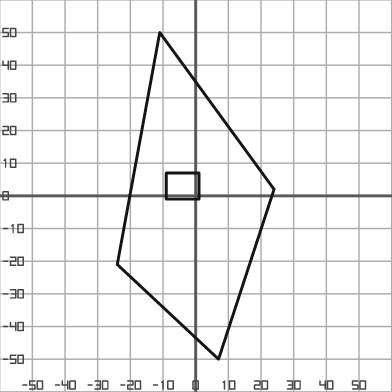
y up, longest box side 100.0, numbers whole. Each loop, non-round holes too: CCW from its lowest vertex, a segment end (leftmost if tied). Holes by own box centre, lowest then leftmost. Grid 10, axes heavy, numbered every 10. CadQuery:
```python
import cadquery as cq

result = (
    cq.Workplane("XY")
    .moveTo(7.0, -50.0)
    .lineTo(24.0, 2.0)
    .lineTo(-11.0, 50.0)
    .lineTo(-24.0, -21.0)
    .close()
    .moveTo(-9.0, -1.0)
    .lineTo(1.0, -1.0)
    .lineTo(1.0, 7.0)
    .lineTo(-9.0, 7.0)
    .close()
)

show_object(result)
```